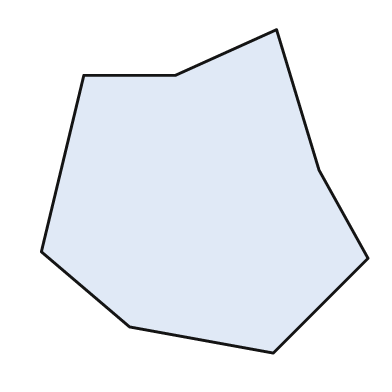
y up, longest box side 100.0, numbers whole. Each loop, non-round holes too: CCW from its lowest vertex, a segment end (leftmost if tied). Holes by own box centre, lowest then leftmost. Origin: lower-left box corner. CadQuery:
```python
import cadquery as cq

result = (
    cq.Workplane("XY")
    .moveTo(71.0, 0.0)
    .lineTo(100.0, 29.0)
    .lineTo(85.0, 56.0)
    .lineTo(72.0, 99.0)
    .lineTo(41.0, 85.0)
    .lineTo(13.0, 85.0)
    .lineTo(0.0, 31.0)
    .lineTo(27.0, 8.0)
    .close()
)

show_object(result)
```